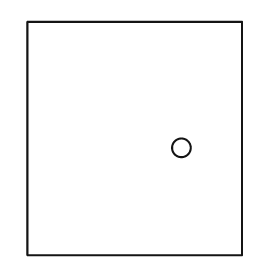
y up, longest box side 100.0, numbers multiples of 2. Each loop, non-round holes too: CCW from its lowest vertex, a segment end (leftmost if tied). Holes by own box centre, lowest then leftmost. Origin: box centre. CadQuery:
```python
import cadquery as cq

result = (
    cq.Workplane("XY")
    .moveTo(-46.0, -50.0)
    .lineTo(46.0, -50.0)
    .lineTo(46.0, 50.0)
    .lineTo(-46.0, 50.0)
    .close()
    .moveTo(20.0, -4.0)
    .circle(4.0)
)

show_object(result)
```